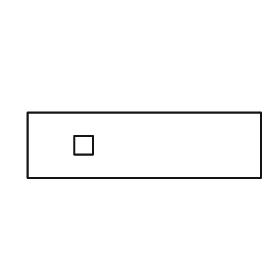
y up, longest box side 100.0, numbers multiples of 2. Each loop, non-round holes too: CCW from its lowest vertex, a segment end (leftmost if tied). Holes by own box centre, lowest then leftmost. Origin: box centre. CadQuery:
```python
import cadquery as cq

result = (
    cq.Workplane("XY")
    .moveTo(-50.0, -14.0)
    .lineTo(50.0, -14.0)
    .lineTo(50.0, 14.0)
    .lineTo(-50.0, 14.0)
    .close()
    .moveTo(-30.0, -4.0)
    .lineTo(-22.0, -4.0)
    .lineTo(-22.0, 4.0)
    .lineTo(-30.0, 4.0)
    .close()
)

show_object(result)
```